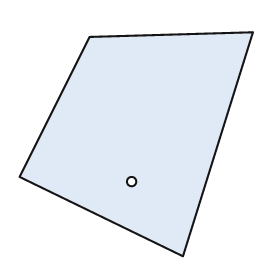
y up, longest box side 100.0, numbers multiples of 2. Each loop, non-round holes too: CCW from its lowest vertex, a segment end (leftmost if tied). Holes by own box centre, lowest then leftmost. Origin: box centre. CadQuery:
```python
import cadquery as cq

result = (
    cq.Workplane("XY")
    .moveTo(20.0, -48.0)
    .lineTo(50.0, 48.0)
    .lineTo(-20.0, 46.0)
    .lineTo(-50.0, -14.0)
    .close()
    .moveTo(-2.0, -16.0)
    .circle(2.0)
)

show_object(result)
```